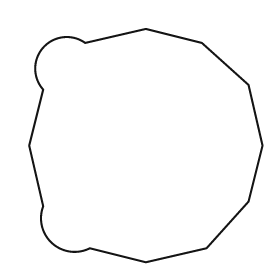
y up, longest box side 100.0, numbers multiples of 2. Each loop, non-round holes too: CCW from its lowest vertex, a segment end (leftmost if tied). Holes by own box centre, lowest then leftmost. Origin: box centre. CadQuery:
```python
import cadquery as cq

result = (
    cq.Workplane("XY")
    .moveTo(0.0, -50.0)
    .lineTo(26.0, -44.0)
    .lineTo(44.0, -24.0)
    .lineTo(50.0, 0.0)
    .lineTo(44.0, 26.0)
    .lineTo(24.0, 44.0)
    .lineTo(0.0, 50.0)
    .lineTo(-26.0, 44.0)
    .threePointArc((-44.0, 42.0), (-44.0, 24.0))
    .lineTo(-50.0, 0.0)
    .lineTo(-44.0, -26.0)
    .threePointArc((-40.0, -42.0), (-24.0, -44.0))
    .close()
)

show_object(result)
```